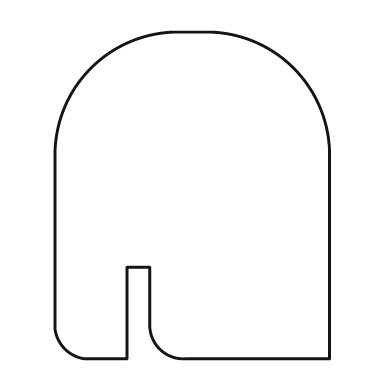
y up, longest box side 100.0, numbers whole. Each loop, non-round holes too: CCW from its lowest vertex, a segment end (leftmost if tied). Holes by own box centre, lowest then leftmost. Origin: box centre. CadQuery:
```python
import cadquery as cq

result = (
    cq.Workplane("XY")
    .moveTo(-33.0, -50.0)
    .lineTo(-20.0, -50.0)
    .lineTo(-20.0, -22.0)
    .lineTo(-13.0, -22.0)
    .lineTo(-13.0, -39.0)
    .threePointArc((-10.0, -47.0), (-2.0, -50.0))
    .lineTo(42.0, -50.0)
    .lineTo(42.0, 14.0)
    .threePointArc((31.0, 39.0), (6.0, 50.0))
    .lineTo(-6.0, 50.0)
    .threePointArc((-31.0, 39.0), (-42.0, 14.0))
    .lineTo(-42.0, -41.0)
    .threePointArc((-39.0, -47.0), (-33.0, -50.0))
    .close()
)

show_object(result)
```